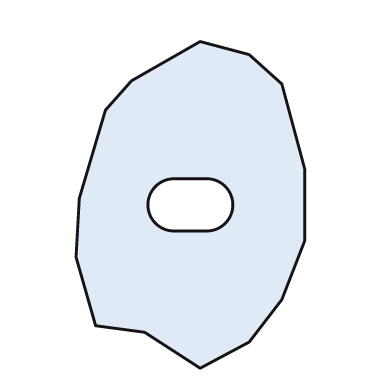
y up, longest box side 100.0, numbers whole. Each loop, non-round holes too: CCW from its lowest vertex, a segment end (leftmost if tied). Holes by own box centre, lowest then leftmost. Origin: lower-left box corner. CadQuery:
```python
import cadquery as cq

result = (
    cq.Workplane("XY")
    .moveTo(38.0, 0.0)
    .lineTo(53.0, 8.0)
    .lineTo(63.0, 21.0)
    .lineTo(70.0, 39.0)
    .lineTo(70.0, 61.0)
    .lineTo(63.0, 87.0)
    .lineTo(53.0, 96.0)
    .lineTo(38.0, 100.0)
    .lineTo(17.0, 88.0)
    .lineTo(9.0, 79.0)
    .lineTo(1.0, 52.0)
    .lineTo(0.0, 34.0)
    .lineTo(6.0, 13.0)
    .lineTo(21.0, 11.0)
    .close()
    .moveTo(30.0, 42.0)
    .lineTo(40.0, 42.0)
    .threePointArc((48.0, 50.0), (40.0, 58.0))
    .lineTo(30.0, 58.0)
    .threePointArc((22.0, 50.0), (30.0, 42.0))
    .close()
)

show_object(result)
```